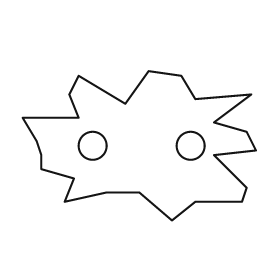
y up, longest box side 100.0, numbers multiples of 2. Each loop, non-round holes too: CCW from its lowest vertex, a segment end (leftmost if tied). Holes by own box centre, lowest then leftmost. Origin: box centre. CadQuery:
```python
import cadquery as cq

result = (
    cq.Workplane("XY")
    .moveTo(14.0, -32.0)
    .lineTo(24.0, -24.0)
    .lineTo(44.0, -24.0)
    .lineTo(46.0, -18.0)
    .lineTo(32.0, -4.0)
    .lineTo(50.0, -2.0)
    .lineTo(46.0, 6.0)
    .lineTo(32.0, 10.0)
    .lineTo(48.0, 22.0)
    .lineTo(24.0, 20.0)
    .lineTo(18.0, 30.0)
    .lineTo(4.0, 32.0)
    .lineTo(-6.0, 18.0)
    .lineTo(-26.0, 30.0)
    .lineTo(-30.0, 22.0)
    .lineTo(-26.0, 12.0)
    .lineTo(-50.0, 12.0)
    .lineTo(-44.0, 2.0)
    .lineTo(-42.0, -4.0)
    .lineTo(-42.0, -10.0)
    .lineTo(-28.0, -14.0)
    .lineTo(-32.0, -24.0)
    .lineTo(-14.0, -20.0)
    .lineTo(0.0, -20.0)
    .close()
    .moveTo(-20.0, 0.0)
    .circle(6.0)
    .moveTo(22.0, 0.0)
    .circle(6.0)
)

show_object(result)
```